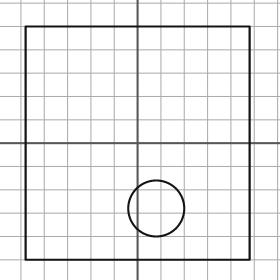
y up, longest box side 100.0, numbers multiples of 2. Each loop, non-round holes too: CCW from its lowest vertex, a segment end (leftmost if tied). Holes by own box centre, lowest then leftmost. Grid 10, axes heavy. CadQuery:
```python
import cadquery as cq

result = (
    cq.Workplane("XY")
    .moveTo(-48.0, -50.0)
    .lineTo(48.0, -50.0)
    .lineTo(48.0, 50.0)
    .lineTo(-48.0, 50.0)
    .close()
    .moveTo(8.0, -28.0)
    .circle(12.0)
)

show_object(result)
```